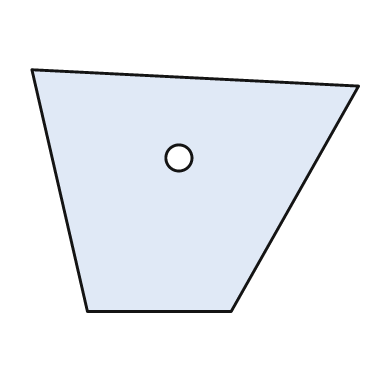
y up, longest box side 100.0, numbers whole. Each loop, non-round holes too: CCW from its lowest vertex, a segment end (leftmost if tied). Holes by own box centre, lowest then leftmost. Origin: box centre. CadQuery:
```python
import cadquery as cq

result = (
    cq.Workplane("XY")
    .moveTo(-33.0, -37.0)
    .lineTo(11.0, -37.0)
    .lineTo(50.0, 32.0)
    .lineTo(-50.0, 37.0)
    .close()
    .moveTo(-5.0, 10.0)
    .circle(4.0)
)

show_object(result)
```